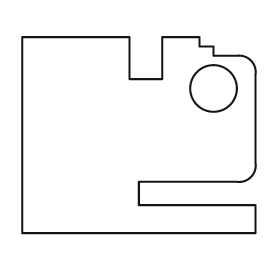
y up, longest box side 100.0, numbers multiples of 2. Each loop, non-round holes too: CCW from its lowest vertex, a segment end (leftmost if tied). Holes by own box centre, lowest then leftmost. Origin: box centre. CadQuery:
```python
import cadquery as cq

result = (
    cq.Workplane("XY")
    .moveTo(-50.0, -42.0)
    .lineTo(50.0, -42.0)
    .lineTo(50.0, -30.0)
    .lineTo(0.0, -30.0)
    .lineTo(0.0, -20.0)
    .lineTo(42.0, -20.0)
    .threePointArc((48.0, -18.0), (50.0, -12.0))
    .lineTo(50.0, 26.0)
    .threePointArc((48.0, 32.0), (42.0, 34.0))
    .lineTo(32.0, 34.0)
    .lineTo(32.0, 38.0)
    .lineTo(26.0, 38.0)
    .lineTo(26.0, 42.0)
    .lineTo(10.0, 42.0)
    .lineTo(10.0, 24.0)
    .lineTo(-4.0, 24.0)
    .lineTo(-4.0, 42.0)
    .lineTo(-50.0, 42.0)
    .close()
    .moveTo(32.0, 20.0)
    .circle(10.0)
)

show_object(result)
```